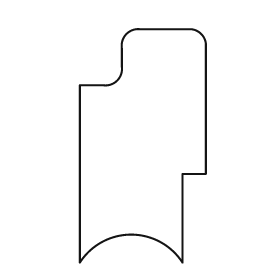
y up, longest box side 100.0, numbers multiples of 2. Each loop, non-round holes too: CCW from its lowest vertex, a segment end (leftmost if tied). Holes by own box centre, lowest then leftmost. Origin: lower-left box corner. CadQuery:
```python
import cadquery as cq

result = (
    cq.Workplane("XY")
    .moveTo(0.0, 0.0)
    .threePointArc((22.0, 12.0), (44.0, 0.0))
    .lineTo(44.0, 38.0)
    .lineTo(54.0, 38.0)
    .lineTo(54.0, 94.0)
    .threePointArc((52.0, 98.0), (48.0, 100.0))
    .lineTo(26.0, 100.0)
    .threePointArc((20.0, 98.0), (18.0, 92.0))
    .lineTo(18.0, 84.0)
    .threePointArc((16.0, 78.0), (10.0, 76.0))
    .lineTo(0.0, 76.0)
    .close()
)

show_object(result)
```